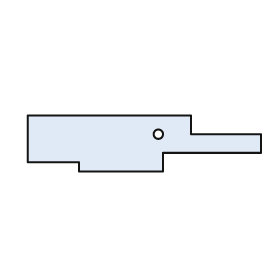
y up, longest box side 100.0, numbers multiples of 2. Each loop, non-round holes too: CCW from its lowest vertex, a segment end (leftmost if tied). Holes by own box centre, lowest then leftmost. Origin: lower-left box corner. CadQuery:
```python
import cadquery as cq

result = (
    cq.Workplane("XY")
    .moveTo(22.0, 0.0)
    .lineTo(58.0, 0.0)
    .lineTo(58.0, 8.0)
    .lineTo(100.0, 8.0)
    .lineTo(100.0, 16.0)
    .lineTo(70.0, 16.0)
    .lineTo(70.0, 24.0)
    .lineTo(0.0, 24.0)
    .lineTo(0.0, 4.0)
    .lineTo(22.0, 4.0)
    .close()
    .moveTo(56.0, 16.0)
    .circle(2.0)
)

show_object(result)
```